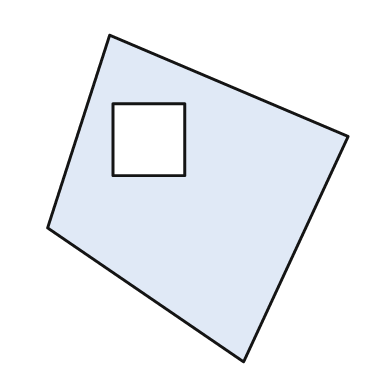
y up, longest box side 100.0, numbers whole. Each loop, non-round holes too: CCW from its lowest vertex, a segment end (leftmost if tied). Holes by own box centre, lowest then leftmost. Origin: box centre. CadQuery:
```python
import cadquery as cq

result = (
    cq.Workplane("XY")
    .moveTo(14.0, -50.0)
    .lineTo(46.0, 19.0)
    .lineTo(-27.0, 50.0)
    .lineTo(-46.0, -9.0)
    .close()
    .moveTo(-26.0, 7.0)
    .lineTo(-4.0, 7.0)
    .lineTo(-4.0, 29.0)
    .lineTo(-26.0, 29.0)
    .close()
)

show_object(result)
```